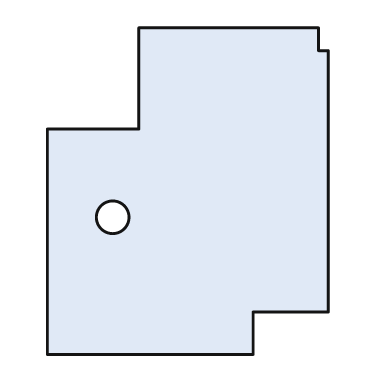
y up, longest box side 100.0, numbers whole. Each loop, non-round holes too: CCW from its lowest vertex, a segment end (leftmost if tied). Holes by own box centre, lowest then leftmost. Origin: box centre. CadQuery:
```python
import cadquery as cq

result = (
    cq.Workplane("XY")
    .moveTo(-43.0, -50.0)
    .lineTo(20.0, -50.0)
    .lineTo(20.0, -37.0)
    .lineTo(43.0, -37.0)
    .lineTo(43.0, 43.0)
    .lineTo(40.0, 43.0)
    .lineTo(40.0, 50.0)
    .lineTo(-15.0, 50.0)
    .lineTo(-15.0, 19.0)
    .lineTo(-43.0, 19.0)
    .close()
    .moveTo(-23.0, -8.0)
    .circle(5.0)
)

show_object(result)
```